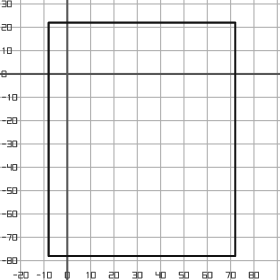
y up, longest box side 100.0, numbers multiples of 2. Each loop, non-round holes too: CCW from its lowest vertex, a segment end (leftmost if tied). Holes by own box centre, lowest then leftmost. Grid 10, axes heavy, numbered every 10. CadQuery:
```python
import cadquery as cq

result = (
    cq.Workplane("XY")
    .moveTo(-8.0, -78.0)
    .lineTo(72.0, -78.0)
    .lineTo(72.0, 22.0)
    .lineTo(-8.0, 22.0)
    .close()
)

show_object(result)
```